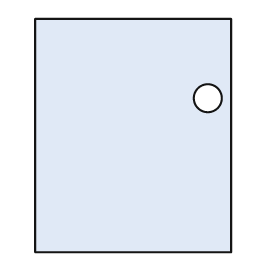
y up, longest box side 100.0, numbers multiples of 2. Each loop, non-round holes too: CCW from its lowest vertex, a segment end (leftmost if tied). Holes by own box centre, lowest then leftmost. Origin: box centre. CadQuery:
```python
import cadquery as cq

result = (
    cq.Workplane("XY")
    .moveTo(-42.0, -50.0)
    .lineTo(42.0, -50.0)
    .lineTo(42.0, 50.0)
    .lineTo(-42.0, 50.0)
    .close()
    .moveTo(32.0, 16.0)
    .circle(6.0)
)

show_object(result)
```